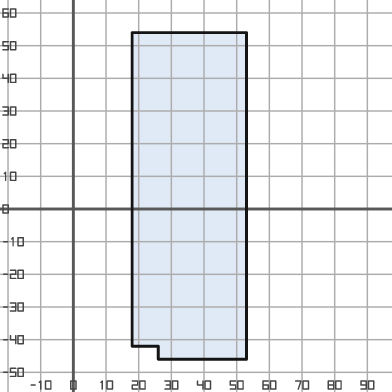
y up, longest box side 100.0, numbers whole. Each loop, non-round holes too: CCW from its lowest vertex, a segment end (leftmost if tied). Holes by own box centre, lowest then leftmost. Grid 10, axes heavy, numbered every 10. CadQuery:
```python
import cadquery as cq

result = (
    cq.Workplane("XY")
    .moveTo(26.0, -46.0)
    .lineTo(53.0, -46.0)
    .lineTo(53.0, 54.0)
    .lineTo(18.0, 54.0)
    .lineTo(18.0, -42.0)
    .lineTo(26.0, -42.0)
    .close()
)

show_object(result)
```